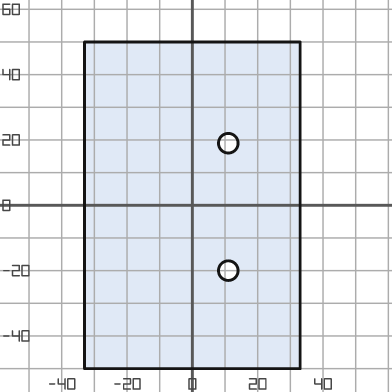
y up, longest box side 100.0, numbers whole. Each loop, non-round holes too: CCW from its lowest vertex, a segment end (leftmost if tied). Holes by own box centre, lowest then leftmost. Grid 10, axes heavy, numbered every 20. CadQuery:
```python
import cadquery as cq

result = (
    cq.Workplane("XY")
    .moveTo(-33.0, -50.0)
    .lineTo(33.0, -50.0)
    .lineTo(33.0, 50.0)
    .lineTo(-33.0, 50.0)
    .close()
    .moveTo(11.0, -20.0)
    .circle(3.0)
    .moveTo(11.0, 19.0)
    .circle(3.0)
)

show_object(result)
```